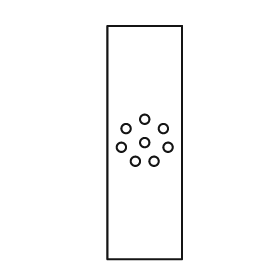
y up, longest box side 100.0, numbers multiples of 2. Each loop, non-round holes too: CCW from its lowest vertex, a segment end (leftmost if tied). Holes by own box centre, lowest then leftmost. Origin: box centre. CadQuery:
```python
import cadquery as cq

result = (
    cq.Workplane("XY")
    .moveTo(-16.0, -50.0)
    .lineTo(16.0, -50.0)
    .lineTo(16.0, 50.0)
    .lineTo(-16.0, 50.0)
    .close()
    .moveTo(-4.0, -8.0)
    .circle(2.0)
    .moveTo(4.0, -8.0)
    .circle(2.0)
    .moveTo(-10.0, -2.0)
    .circle(2.0)
    .moveTo(10.0, -2.0)
    .circle(2.0)
    .moveTo(0.0, 0.0)
    .circle(2.0)
    .moveTo(-8.0, 6.0)
    .circle(2.0)
    .moveTo(8.0, 6.0)
    .circle(2.0)
    .moveTo(0.0, 10.0)
    .circle(2.0)
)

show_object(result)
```